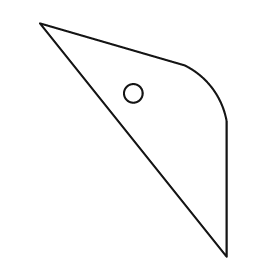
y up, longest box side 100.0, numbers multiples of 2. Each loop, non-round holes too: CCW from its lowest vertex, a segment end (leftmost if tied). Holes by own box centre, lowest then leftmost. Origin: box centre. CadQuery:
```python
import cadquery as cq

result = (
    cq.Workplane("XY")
    .moveTo(40.0, -50.0)
    .lineTo(40.0, 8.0)
    .threePointArc((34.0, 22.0), (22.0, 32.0))
    .lineTo(-40.0, 50.0)
    .close()
    .moveTo(0.0, 20.0)
    .circle(4.0)
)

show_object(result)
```